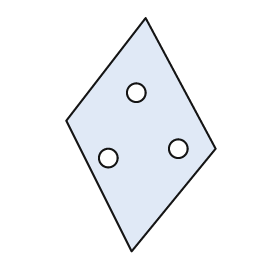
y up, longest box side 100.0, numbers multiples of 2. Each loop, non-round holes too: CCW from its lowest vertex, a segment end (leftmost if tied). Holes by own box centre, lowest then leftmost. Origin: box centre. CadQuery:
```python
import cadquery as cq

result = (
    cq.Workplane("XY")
    .moveTo(-4.0, -50.0)
    .lineTo(32.0, -6.0)
    .lineTo(2.0, 50.0)
    .lineTo(-32.0, 6.0)
    .close()
    .moveTo(-14.0, -10.0)
    .circle(4.0)
    .moveTo(16.0, -6.0)
    .circle(4.0)
    .moveTo(-2.0, 18.0)
    .circle(4.0)
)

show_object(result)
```